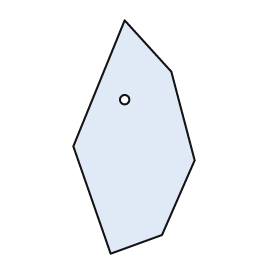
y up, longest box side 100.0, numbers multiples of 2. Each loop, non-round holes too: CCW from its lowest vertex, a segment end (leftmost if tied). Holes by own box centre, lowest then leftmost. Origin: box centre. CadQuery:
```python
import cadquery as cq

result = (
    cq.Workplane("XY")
    .moveTo(-10.0, -50.0)
    .lineTo(12.0, -42.0)
    .lineTo(26.0, -10.0)
    .lineTo(16.0, 28.0)
    .lineTo(-4.0, 50.0)
    .lineTo(-26.0, -4.0)
    .close()
    .moveTo(-4.0, 16.0)
    .circle(2.0)
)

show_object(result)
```